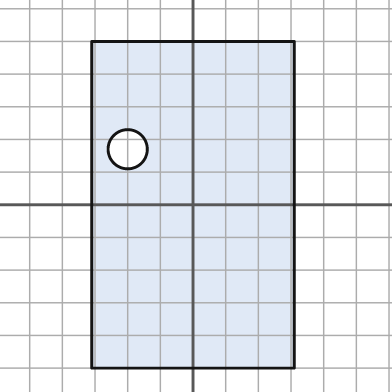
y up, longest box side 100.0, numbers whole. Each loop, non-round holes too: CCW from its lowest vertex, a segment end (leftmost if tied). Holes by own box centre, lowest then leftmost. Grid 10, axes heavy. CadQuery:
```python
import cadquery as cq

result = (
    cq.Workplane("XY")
    .moveTo(-31.0, -50.0)
    .lineTo(31.0, -50.0)
    .lineTo(31.0, 50.0)
    .lineTo(-31.0, 50.0)
    .close()
    .moveTo(-20.0, 17.0)
    .circle(6.0)
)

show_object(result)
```